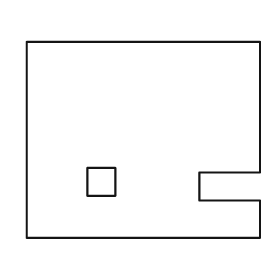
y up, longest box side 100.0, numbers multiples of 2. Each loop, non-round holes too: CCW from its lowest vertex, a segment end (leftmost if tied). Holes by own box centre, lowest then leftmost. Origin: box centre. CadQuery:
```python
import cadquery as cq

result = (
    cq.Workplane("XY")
    .moveTo(-50.0, -42.0)
    .lineTo(50.0, -42.0)
    .lineTo(50.0, -26.0)
    .lineTo(24.0, -26.0)
    .lineTo(24.0, -14.0)
    .lineTo(50.0, -14.0)
    .lineTo(50.0, 42.0)
    .lineTo(-50.0, 42.0)
    .close()
    .moveTo(-24.0, -24.0)
    .lineTo(-12.0, -24.0)
    .lineTo(-12.0, -12.0)
    .lineTo(-24.0, -12.0)
    .close()
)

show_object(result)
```